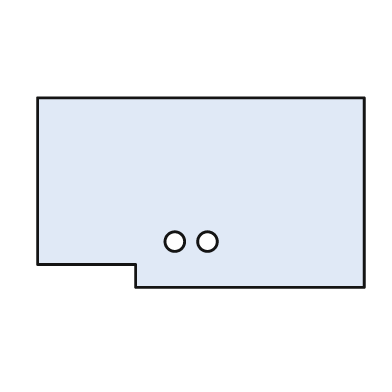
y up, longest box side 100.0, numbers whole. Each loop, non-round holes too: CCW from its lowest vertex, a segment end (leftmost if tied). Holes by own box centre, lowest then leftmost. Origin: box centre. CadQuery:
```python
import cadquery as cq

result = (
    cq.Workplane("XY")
    .moveTo(-20.0, -29.0)
    .lineTo(50.0, -29.0)
    .lineTo(50.0, 29.0)
    .lineTo(-50.0, 29.0)
    .lineTo(-50.0, -22.0)
    .lineTo(-20.0, -22.0)
    .close()
    .moveTo(-8.0, -15.0)
    .circle(3.0)
    .moveTo(2.0, -15.0)
    .circle(3.0)
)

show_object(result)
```